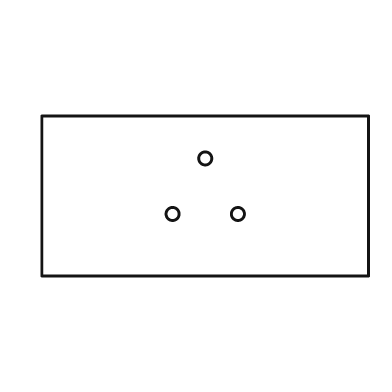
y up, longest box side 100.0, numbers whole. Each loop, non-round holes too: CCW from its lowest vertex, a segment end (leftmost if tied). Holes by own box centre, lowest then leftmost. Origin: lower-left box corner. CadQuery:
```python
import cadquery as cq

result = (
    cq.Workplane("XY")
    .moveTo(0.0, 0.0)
    .lineTo(100.0, 0.0)
    .lineTo(100.0, 49.0)
    .lineTo(0.0, 49.0)
    .close()
    .moveTo(40.0, 19.0)
    .circle(2.0)
    .moveTo(60.0, 19.0)
    .circle(2.0)
    .moveTo(50.0, 36.0)
    .circle(2.0)
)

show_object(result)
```